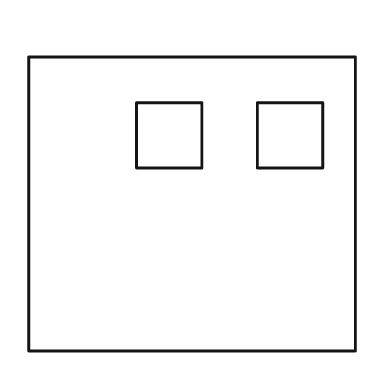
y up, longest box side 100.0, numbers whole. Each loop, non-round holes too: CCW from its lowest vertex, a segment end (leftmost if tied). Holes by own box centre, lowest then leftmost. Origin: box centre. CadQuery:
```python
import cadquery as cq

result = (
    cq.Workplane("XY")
    .moveTo(-50.0, -45.0)
    .lineTo(50.0, -45.0)
    .lineTo(50.0, 45.0)
    .lineTo(-50.0, 45.0)
    .close()
    .moveTo(-17.0, 11.0)
    .lineTo(3.0, 11.0)
    .lineTo(3.0, 31.0)
    .lineTo(-17.0, 31.0)
    .close()
    .moveTo(20.0, 11.0)
    .lineTo(40.0, 11.0)
    .lineTo(40.0, 31.0)
    .lineTo(20.0, 31.0)
    .close()
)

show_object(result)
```